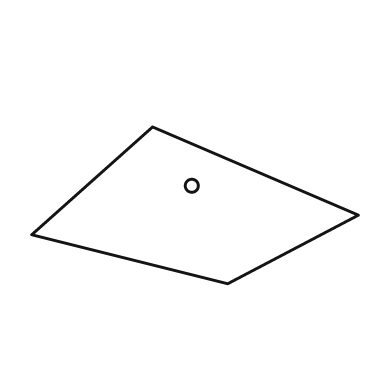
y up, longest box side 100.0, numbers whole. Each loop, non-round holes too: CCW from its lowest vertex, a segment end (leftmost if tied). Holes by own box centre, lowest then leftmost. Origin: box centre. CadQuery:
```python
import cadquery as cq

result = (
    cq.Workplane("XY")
    .moveTo(10.0, -24.0)
    .lineTo(50.0, -3.0)
    .lineTo(-13.0, 24.0)
    .lineTo(-50.0, -9.0)
    .close()
    .moveTo(-1.0, 6.0)
    .circle(2.0)
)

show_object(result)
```